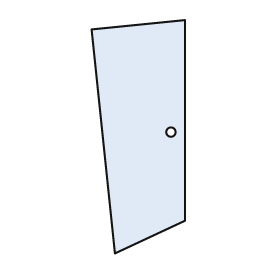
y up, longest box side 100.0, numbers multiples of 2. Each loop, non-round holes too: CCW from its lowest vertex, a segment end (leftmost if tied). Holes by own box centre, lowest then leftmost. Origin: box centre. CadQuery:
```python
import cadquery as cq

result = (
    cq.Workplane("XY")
    .moveTo(-10.0, -50.0)
    .lineTo(20.0, -36.0)
    .lineTo(20.0, 50.0)
    .lineTo(-20.0, 46.0)
    .close()
    .moveTo(14.0, 2.0)
    .circle(2.0)
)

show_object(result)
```